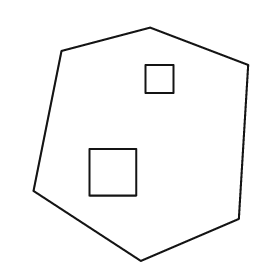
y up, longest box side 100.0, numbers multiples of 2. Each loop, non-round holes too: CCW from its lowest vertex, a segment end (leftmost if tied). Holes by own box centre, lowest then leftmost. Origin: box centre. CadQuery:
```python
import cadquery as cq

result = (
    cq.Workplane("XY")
    .moveTo(0.0, -50.0)
    .lineTo(42.0, -32.0)
    .lineTo(46.0, 34.0)
    .lineTo(4.0, 50.0)
    .lineTo(-34.0, 40.0)
    .lineTo(-46.0, -20.0)
    .close()
    .moveTo(-22.0, -22.0)
    .lineTo(-2.0, -22.0)
    .lineTo(-2.0, -2.0)
    .lineTo(-22.0, -2.0)
    .close()
    .moveTo(2.0, 22.0)
    .lineTo(14.0, 22.0)
    .lineTo(14.0, 34.0)
    .lineTo(2.0, 34.0)
    .close()
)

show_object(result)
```